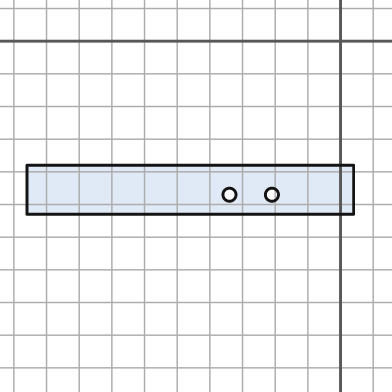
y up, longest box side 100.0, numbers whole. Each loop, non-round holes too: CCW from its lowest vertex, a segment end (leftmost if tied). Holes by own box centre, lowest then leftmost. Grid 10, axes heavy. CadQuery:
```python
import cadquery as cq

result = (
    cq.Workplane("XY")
    .moveTo(-96.0, -53.0)
    .lineTo(4.0, -53.0)
    .lineTo(4.0, -38.0)
    .lineTo(-96.0, -38.0)
    .close()
    .moveTo(-34.0, -47.0)
    .circle(2.0)
    .moveTo(-21.0, -47.0)
    .circle(2.0)
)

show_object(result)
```